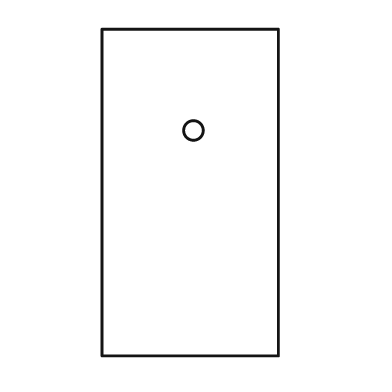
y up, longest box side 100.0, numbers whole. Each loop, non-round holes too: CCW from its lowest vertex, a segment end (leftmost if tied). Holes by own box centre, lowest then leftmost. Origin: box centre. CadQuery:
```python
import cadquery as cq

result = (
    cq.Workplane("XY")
    .moveTo(-27.0, -50.0)
    .lineTo(27.0, -50.0)
    .lineTo(27.0, 50.0)
    .lineTo(-27.0, 50.0)
    .close()
    .moveTo(1.0, 19.0)
    .circle(3.0)
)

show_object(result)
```